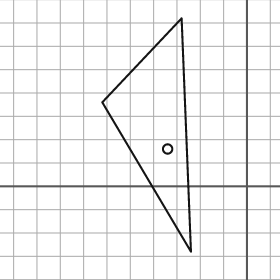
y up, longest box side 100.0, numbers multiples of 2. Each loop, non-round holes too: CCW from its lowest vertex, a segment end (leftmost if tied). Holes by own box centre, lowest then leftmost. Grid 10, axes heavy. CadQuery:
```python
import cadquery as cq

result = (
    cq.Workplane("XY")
    .moveTo(-24.0, -28.0)
    .lineTo(-28.0, 72.0)
    .lineTo(-62.0, 36.0)
    .close()
    .moveTo(-34.0, 16.0)
    .circle(2.0)
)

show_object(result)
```